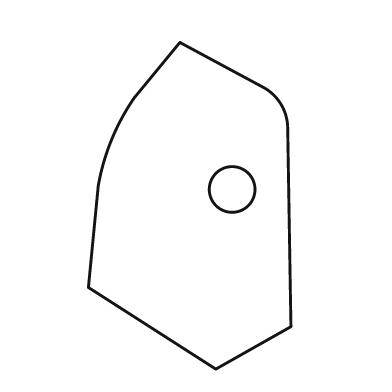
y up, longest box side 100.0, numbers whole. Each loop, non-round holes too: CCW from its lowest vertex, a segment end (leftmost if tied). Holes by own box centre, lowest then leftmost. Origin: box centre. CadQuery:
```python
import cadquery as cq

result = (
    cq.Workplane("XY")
    .moveTo(8.0, -50.0)
    .lineTo(31.0, -37.0)
    .lineTo(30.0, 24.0)
    .threePointArc((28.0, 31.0), (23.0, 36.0))
    .lineTo(-3.0, 50.0)
    .lineTo(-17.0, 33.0)
    .threePointArc((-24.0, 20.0), (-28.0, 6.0))
    .lineTo(-31.0, -25.0)
    .close()
    .moveTo(13.0, 5.0)
    .circle(7.0)
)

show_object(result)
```